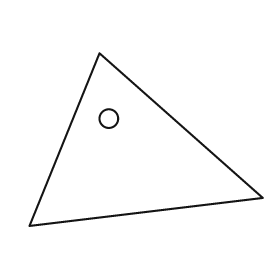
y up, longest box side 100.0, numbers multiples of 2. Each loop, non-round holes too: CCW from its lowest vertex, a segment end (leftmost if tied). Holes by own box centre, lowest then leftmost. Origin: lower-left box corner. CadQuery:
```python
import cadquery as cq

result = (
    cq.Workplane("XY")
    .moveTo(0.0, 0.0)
    .lineTo(100.0, 12.0)
    .lineTo(30.0, 74.0)
    .close()
    .moveTo(34.0, 46.0)
    .circle(4.0)
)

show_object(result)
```